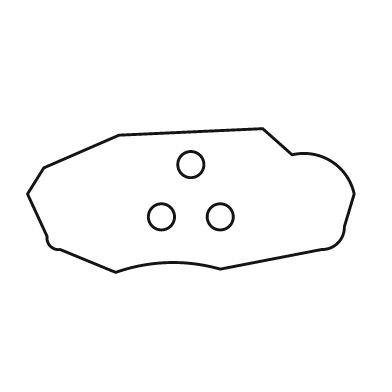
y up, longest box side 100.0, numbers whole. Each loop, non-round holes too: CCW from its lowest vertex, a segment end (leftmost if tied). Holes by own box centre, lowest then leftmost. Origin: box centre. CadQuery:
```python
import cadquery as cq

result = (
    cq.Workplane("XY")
    .moveTo(-23.0, -22.0)
    .threePointArc((-7.0, -19.0), (9.0, -21.0))
    .lineTo(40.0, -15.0)
    .threePointArc((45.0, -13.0), (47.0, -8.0))
    .lineTo(50.0, 2.0)
    .threePointArc((43.0, 12.0), (31.0, 14.0))
    .lineTo(22.0, 22.0)
    .lineTo(-22.0, 20.0)
    .lineTo(-45.0, 10.0)
    .lineTo(-50.0, 2.0)
    .lineTo(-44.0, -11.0)
    .threePointArc((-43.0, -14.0), (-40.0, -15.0))
    .close()
    .moveTo(-9.0, -5.0)
    .circle(4.0)
    .moveTo(9.0, -5.0)
    .circle(4.0)
    .moveTo(0.0, 11.0)
    .circle(4.0)
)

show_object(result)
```